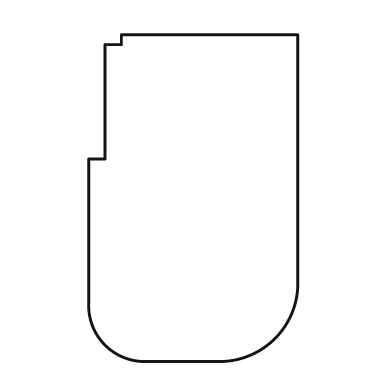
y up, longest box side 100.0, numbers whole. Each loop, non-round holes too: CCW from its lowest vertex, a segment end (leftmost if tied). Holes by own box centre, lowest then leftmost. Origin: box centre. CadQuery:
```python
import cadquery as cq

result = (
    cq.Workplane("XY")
    .moveTo(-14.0, -50.0)
    .lineTo(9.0, -50.0)
    .threePointArc((25.0, -43.0), (32.0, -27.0))
    .lineTo(32.0, 50.0)
    .lineTo(-22.0, 50.0)
    .lineTo(-22.0, 47.0)
    .lineTo(-27.0, 47.0)
    .lineTo(-27.0, 12.0)
    .lineTo(-32.0, 12.0)
    .lineTo(-32.0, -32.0)
    .threePointArc((-27.0, -45.0), (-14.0, -50.0))
    .close()
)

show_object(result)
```